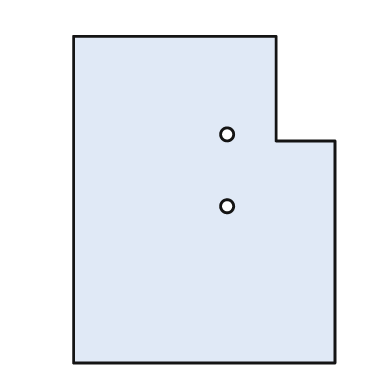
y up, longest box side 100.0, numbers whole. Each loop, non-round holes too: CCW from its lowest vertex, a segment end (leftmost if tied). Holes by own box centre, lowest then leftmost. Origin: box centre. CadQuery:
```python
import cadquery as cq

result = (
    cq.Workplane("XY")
    .moveTo(-40.0, -50.0)
    .lineTo(40.0, -50.0)
    .lineTo(40.0, 18.0)
    .lineTo(22.0, 18.0)
    .lineTo(22.0, 50.0)
    .lineTo(-40.0, 50.0)
    .close()
    .moveTo(7.0, -2.0)
    .circle(2.0)
    .moveTo(7.0, 20.0)
    .circle(2.0)
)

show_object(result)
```